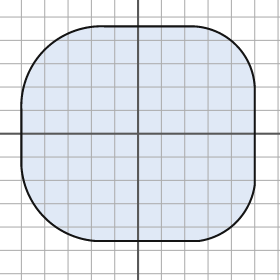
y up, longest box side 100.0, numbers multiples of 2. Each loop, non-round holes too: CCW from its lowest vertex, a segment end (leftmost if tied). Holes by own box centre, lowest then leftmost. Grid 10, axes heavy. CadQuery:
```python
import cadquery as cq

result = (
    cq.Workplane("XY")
    .moveTo(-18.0, -46.0)
    .lineTo(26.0, -46.0)
    .threePointArc((42.0, -38.0), (50.0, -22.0))
    .lineTo(50.0, 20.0)
    .threePointArc((42.0, 38.0), (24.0, 46.0))
    .lineTo(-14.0, 46.0)
    .threePointArc((-40.0, 36.0), (-50.0, 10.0))
    .lineTo(-50.0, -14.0)
    .threePointArc((-40.0, -36.0), (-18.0, -46.0))
    .close()
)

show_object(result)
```